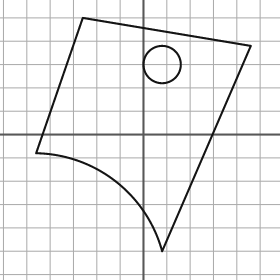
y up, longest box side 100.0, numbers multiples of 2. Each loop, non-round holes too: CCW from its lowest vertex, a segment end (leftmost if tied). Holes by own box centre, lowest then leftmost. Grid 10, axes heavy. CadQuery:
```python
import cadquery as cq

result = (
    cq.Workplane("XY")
    .moveTo(8.0, -50.0)
    .lineTo(46.0, 38.0)
    .lineTo(-26.0, 50.0)
    .lineTo(-46.0, -8.0)
    .threePointArc((-12.0, -20.0), (8.0, -50.0))
    .close()
    .moveTo(8.0, 30.0)
    .circle(8.0)
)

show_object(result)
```